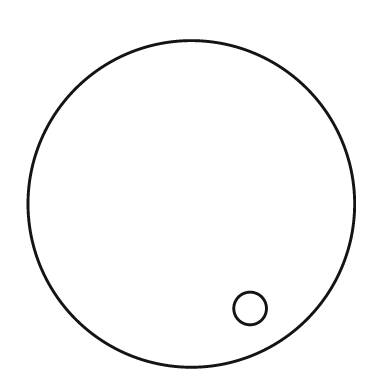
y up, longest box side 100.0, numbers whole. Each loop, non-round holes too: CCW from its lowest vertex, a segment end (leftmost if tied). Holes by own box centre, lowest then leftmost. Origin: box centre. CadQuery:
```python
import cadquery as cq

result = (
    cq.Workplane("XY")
    .moveTo(0.0, 0.0)
    .circle(50.0)
    .moveTo(18.0, -32.0)
    .circle(5.0)
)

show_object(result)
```